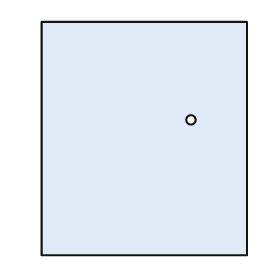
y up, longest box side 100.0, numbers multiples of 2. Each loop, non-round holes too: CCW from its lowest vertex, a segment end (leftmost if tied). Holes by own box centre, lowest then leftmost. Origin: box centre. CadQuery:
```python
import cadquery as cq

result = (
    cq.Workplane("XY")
    .moveTo(-44.0, -50.0)
    .lineTo(44.0, -50.0)
    .lineTo(44.0, 50.0)
    .lineTo(-44.0, 50.0)
    .close()
    .moveTo(20.0, 8.0)
    .circle(2.0)
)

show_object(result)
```